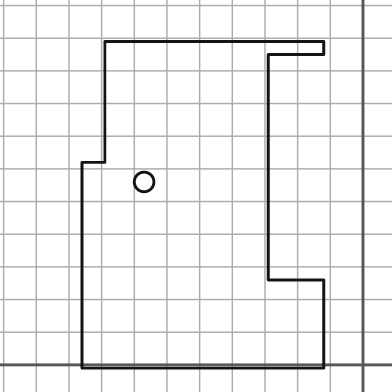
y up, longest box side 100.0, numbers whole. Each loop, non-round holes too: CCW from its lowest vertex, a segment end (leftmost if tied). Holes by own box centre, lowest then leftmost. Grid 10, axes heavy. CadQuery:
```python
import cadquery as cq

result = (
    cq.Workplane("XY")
    .moveTo(-86.0, -1.0)
    .lineTo(-12.0, -1.0)
    .lineTo(-12.0, 26.0)
    .lineTo(-29.0, 26.0)
    .lineTo(-29.0, 95.0)
    .lineTo(-12.0, 95.0)
    .lineTo(-12.0, 99.0)
    .lineTo(-79.0, 99.0)
    .lineTo(-79.0, 62.0)
    .lineTo(-86.0, 62.0)
    .close()
    .moveTo(-67.0, 56.0)
    .circle(3.0)
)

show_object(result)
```